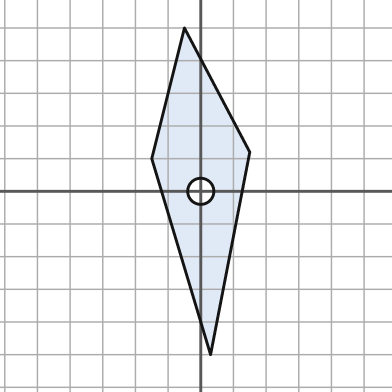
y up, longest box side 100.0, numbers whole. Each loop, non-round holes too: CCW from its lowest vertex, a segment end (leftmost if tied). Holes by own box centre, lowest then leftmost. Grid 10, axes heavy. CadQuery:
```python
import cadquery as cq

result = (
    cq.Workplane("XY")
    .moveTo(3.0, -50.0)
    .lineTo(15.0, 12.0)
    .lineTo(-5.0, 50.0)
    .lineTo(-15.0, 10.0)
    .close()
    .moveTo(0.0, 0.0)
    .circle(4.0)
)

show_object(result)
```